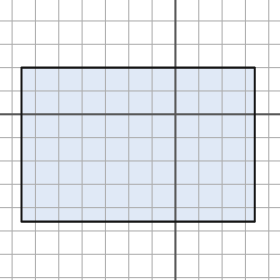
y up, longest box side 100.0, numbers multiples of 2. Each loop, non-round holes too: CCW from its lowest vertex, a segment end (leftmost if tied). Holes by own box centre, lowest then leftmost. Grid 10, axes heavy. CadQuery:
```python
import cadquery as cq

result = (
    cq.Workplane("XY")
    .moveTo(-66.0, -46.0)
    .lineTo(34.0, -46.0)
    .lineTo(34.0, 20.0)
    .lineTo(-66.0, 20.0)
    .close()
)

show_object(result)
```